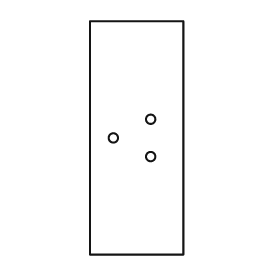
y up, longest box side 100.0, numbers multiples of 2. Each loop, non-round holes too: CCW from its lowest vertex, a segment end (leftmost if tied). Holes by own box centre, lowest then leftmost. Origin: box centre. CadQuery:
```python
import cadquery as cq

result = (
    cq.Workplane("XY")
    .moveTo(-20.0, -50.0)
    .lineTo(20.0, -50.0)
    .lineTo(20.0, 50.0)
    .lineTo(-20.0, 50.0)
    .close()
    .moveTo(6.0, -8.0)
    .circle(2.0)
    .moveTo(-10.0, 0.0)
    .circle(2.0)
    .moveTo(6.0, 8.0)
    .circle(2.0)
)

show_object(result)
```